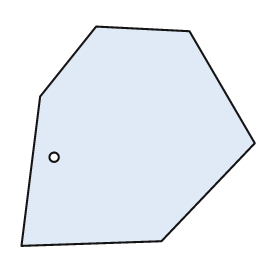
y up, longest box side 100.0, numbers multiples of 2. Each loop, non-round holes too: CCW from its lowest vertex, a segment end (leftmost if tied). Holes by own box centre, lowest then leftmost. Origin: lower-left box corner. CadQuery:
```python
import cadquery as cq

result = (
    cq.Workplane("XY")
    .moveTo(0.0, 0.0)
    .lineTo(60.0, 2.0)
    .lineTo(100.0, 44.0)
    .lineTo(72.0, 92.0)
    .lineTo(32.0, 94.0)
    .lineTo(8.0, 64.0)
    .close()
    .moveTo(14.0, 38.0)
    .circle(2.0)
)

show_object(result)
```